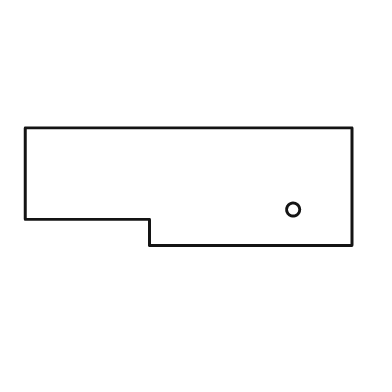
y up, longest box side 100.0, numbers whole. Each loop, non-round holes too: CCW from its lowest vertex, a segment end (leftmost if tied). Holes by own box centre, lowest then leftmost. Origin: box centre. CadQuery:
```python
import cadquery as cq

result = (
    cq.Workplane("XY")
    .moveTo(-12.0, -18.0)
    .lineTo(50.0, -18.0)
    .lineTo(50.0, 18.0)
    .lineTo(-50.0, 18.0)
    .lineTo(-50.0, -10.0)
    .lineTo(-12.0, -10.0)
    .close()
    .moveTo(32.0, -7.0)
    .circle(2.0)
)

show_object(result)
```